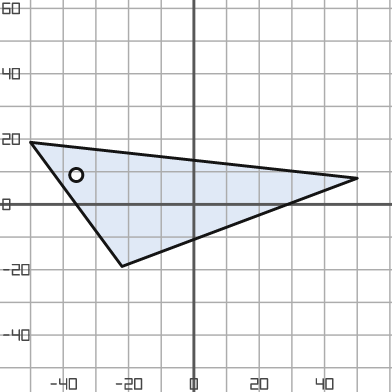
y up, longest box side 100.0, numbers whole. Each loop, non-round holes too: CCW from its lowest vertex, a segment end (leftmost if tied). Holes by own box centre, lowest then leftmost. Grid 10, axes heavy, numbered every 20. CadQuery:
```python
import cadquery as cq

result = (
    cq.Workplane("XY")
    .moveTo(-22.0, -19.0)
    .lineTo(50.0, 8.0)
    .lineTo(-50.0, 19.0)
    .close()
    .moveTo(-36.0, 9.0)
    .circle(2.0)
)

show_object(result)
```